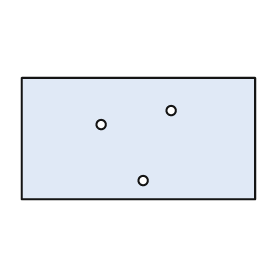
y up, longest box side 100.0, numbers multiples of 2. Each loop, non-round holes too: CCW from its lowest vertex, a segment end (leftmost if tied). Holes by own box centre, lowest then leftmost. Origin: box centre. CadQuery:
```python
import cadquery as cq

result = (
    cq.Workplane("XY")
    .moveTo(-50.0, -26.0)
    .lineTo(50.0, -26.0)
    .lineTo(50.0, 26.0)
    .lineTo(-50.0, 26.0)
    .close()
    .moveTo(2.0, -18.0)
    .circle(2.0)
    .moveTo(-16.0, 6.0)
    .circle(2.0)
    .moveTo(14.0, 12.0)
    .circle(2.0)
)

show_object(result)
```